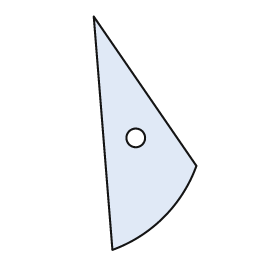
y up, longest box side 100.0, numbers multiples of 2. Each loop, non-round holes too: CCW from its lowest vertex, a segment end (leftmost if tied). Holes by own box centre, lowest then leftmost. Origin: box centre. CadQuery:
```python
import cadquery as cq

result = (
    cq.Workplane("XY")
    .moveTo(-14.0, -50.0)
    .threePointArc((8.0, -36.0), (22.0, -14.0))
    .lineTo(-22.0, 50.0)
    .close()
    .moveTo(-4.0, -2.0)
    .circle(4.0)
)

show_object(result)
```